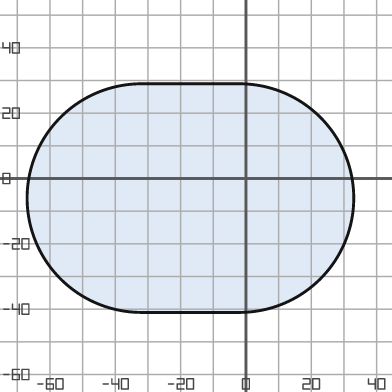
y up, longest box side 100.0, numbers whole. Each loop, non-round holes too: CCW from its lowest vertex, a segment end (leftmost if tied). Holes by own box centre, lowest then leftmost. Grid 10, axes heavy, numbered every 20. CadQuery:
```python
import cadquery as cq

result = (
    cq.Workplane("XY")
    .moveTo(-32.0, -41.0)
    .lineTo(-2.0, -41.0)
    .threePointArc((33.0, -6.0), (-2.0, 29.0))
    .lineTo(-32.0, 29.0)
    .threePointArc((-67.0, -6.0), (-32.0, -41.0))
    .close()
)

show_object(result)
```